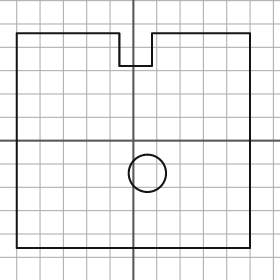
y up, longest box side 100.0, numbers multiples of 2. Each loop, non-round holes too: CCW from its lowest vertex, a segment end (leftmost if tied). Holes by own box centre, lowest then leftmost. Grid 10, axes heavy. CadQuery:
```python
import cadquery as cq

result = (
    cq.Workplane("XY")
    .moveTo(-50.0, -46.0)
    .lineTo(50.0, -46.0)
    .lineTo(50.0, 46.0)
    .lineTo(8.0, 46.0)
    .lineTo(8.0, 32.0)
    .lineTo(-6.0, 32.0)
    .lineTo(-6.0, 46.0)
    .lineTo(-50.0, 46.0)
    .close()
    .moveTo(6.0, -14.0)
    .circle(8.0)
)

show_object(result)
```